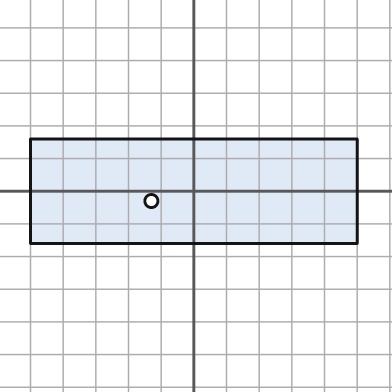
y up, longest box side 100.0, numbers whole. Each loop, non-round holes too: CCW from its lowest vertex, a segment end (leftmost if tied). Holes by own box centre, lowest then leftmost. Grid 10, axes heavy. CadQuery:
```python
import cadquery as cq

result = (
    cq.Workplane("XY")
    .moveTo(-50.0, -16.0)
    .lineTo(50.0, -16.0)
    .lineTo(50.0, 16.0)
    .lineTo(-50.0, 16.0)
    .close()
    .moveTo(-13.0, -3.0)
    .circle(2.0)
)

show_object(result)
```